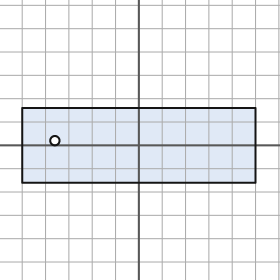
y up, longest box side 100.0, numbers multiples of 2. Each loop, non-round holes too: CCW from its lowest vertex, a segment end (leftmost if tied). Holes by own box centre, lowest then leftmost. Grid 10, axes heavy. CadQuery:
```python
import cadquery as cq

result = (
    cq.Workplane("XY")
    .moveTo(-50.0, -16.0)
    .lineTo(50.0, -16.0)
    .lineTo(50.0, 16.0)
    .lineTo(-50.0, 16.0)
    .close()
    .moveTo(-36.0, 2.0)
    .circle(2.0)
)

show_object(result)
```